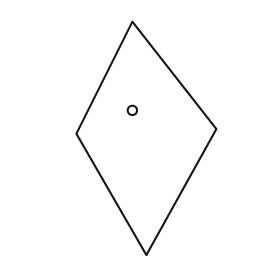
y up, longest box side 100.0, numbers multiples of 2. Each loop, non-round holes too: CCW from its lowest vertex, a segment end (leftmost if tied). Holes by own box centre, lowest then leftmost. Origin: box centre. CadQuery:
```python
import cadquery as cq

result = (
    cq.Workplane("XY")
    .moveTo(0.0, -50.0)
    .lineTo(30.0, 4.0)
    .lineTo(-6.0, 50.0)
    .lineTo(-30.0, 2.0)
    .close()
    .moveTo(-6.0, 12.0)
    .circle(2.0)
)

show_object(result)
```